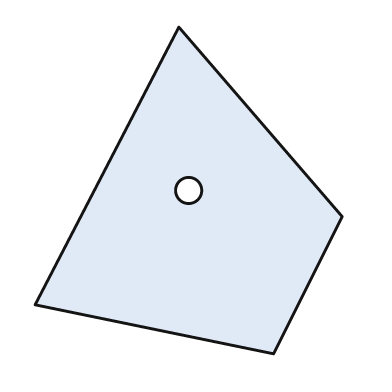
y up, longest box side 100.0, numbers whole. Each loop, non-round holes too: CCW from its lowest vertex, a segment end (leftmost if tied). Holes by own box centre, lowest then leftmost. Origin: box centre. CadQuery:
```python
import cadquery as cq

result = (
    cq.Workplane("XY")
    .moveTo(26.0, -50.0)
    .lineTo(47.0, -8.0)
    .lineTo(-3.0, 50.0)
    .lineTo(-47.0, -35.0)
    .close()
    .moveTo(0.0, 0.0)
    .circle(4.0)
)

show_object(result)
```